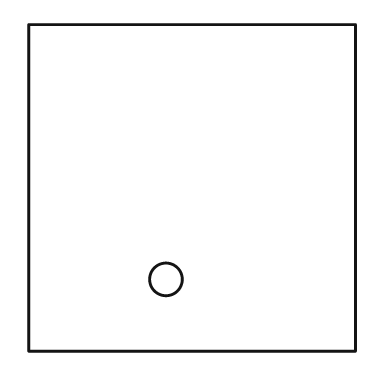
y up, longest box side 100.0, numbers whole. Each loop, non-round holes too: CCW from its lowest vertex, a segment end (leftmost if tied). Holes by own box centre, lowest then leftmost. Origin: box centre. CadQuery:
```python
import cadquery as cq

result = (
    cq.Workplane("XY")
    .moveTo(-50.0, -50.0)
    .lineTo(50.0, -50.0)
    .lineTo(50.0, 50.0)
    .lineTo(-50.0, 50.0)
    .close()
    .moveTo(-8.0, -28.0)
    .circle(5.0)
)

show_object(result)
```